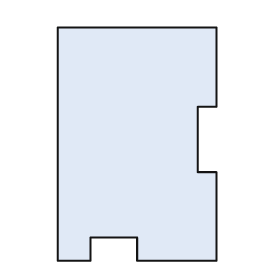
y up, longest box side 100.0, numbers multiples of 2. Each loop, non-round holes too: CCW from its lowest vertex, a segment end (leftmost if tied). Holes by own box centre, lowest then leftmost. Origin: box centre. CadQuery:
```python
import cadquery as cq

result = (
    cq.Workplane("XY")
    .moveTo(-34.0, -50.0)
    .lineTo(-20.0, -50.0)
    .lineTo(-20.0, -40.0)
    .lineTo(0.0, -40.0)
    .lineTo(0.0, -50.0)
    .lineTo(34.0, -50.0)
    .lineTo(34.0, -12.0)
    .lineTo(26.0, -12.0)
    .lineTo(26.0, 16.0)
    .lineTo(34.0, 16.0)
    .lineTo(34.0, 50.0)
    .lineTo(-34.0, 50.0)
    .close()
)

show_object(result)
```